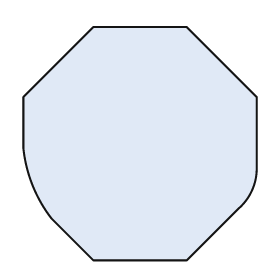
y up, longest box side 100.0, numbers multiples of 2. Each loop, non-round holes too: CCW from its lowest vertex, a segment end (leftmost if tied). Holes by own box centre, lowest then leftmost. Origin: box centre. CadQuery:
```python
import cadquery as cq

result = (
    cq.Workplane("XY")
    .moveTo(-20.0, -50.0)
    .lineTo(20.0, -50.0)
    .lineTo(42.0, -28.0)
    .threePointArc((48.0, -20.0), (50.0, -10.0))
    .lineTo(50.0, 20.0)
    .lineTo(20.0, 50.0)
    .lineTo(-20.0, 50.0)
    .lineTo(-50.0, 20.0)
    .lineTo(-50.0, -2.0)
    .threePointArc((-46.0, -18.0), (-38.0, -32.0))
    .close()
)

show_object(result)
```